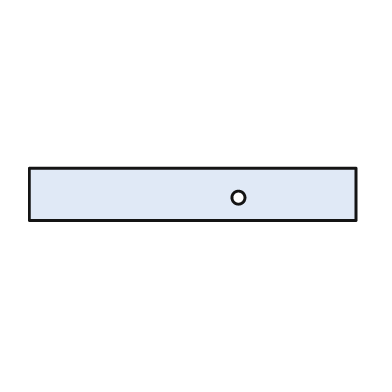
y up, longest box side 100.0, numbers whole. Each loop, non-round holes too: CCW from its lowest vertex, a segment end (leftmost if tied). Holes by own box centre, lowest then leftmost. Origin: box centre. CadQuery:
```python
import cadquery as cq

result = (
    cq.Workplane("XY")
    .moveTo(-50.0, -8.0)
    .lineTo(50.0, -8.0)
    .lineTo(50.0, 8.0)
    .lineTo(-50.0, 8.0)
    .close()
    .moveTo(14.0, -1.0)
    .circle(2.0)
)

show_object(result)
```